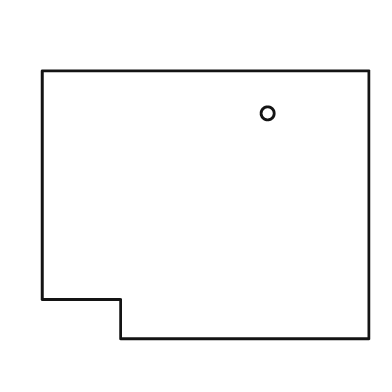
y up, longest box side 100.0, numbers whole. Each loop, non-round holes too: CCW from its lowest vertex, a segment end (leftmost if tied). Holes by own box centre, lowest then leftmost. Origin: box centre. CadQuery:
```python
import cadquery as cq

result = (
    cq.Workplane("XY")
    .moveTo(-26.0, -41.0)
    .lineTo(50.0, -41.0)
    .lineTo(50.0, 41.0)
    .lineTo(-50.0, 41.0)
    .lineTo(-50.0, -29.0)
    .lineTo(-26.0, -29.0)
    .close()
    .moveTo(19.0, 28.0)
    .circle(2.0)
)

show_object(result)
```